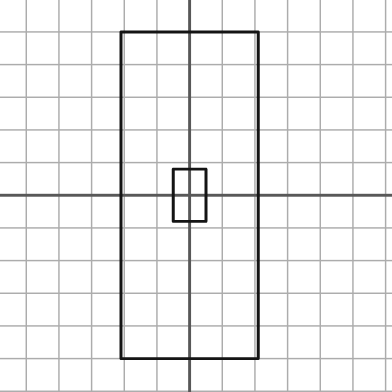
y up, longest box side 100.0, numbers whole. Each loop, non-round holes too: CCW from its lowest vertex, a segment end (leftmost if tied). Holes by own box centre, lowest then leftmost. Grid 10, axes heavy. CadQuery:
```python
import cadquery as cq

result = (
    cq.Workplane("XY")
    .moveTo(-21.0, -50.0)
    .lineTo(21.0, -50.0)
    .lineTo(21.0, 50.0)
    .lineTo(-21.0, 50.0)
    .close()
    .moveTo(-5.0, -8.0)
    .lineTo(5.0, -8.0)
    .lineTo(5.0, 8.0)
    .lineTo(-5.0, 8.0)
    .close()
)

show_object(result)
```